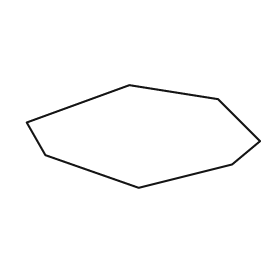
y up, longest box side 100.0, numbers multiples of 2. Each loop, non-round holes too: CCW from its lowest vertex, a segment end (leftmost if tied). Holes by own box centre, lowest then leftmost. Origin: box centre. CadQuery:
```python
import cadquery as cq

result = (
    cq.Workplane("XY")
    .moveTo(-2.0, -22.0)
    .lineTo(38.0, -12.0)
    .lineTo(50.0, -2.0)
    .lineTo(32.0, 16.0)
    .lineTo(-6.0, 22.0)
    .lineTo(-50.0, 6.0)
    .lineTo(-42.0, -8.0)
    .close()
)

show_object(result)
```